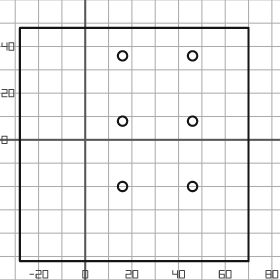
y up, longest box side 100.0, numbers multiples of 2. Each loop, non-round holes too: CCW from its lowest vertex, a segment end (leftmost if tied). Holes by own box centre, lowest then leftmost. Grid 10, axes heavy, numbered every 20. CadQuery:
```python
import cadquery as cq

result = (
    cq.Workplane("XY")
    .moveTo(-28.0, -52.0)
    .lineTo(70.0, -52.0)
    .lineTo(70.0, 48.0)
    .lineTo(-28.0, 48.0)
    .close()
    .moveTo(16.0, -20.0)
    .circle(2.0)
    .moveTo(46.0, -20.0)
    .circle(2.0)
    .moveTo(16.0, 8.0)
    .circle(2.0)
    .moveTo(46.0, 8.0)
    .circle(2.0)
    .moveTo(16.0, 36.0)
    .circle(2.0)
    .moveTo(46.0, 36.0)
    .circle(2.0)
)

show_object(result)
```